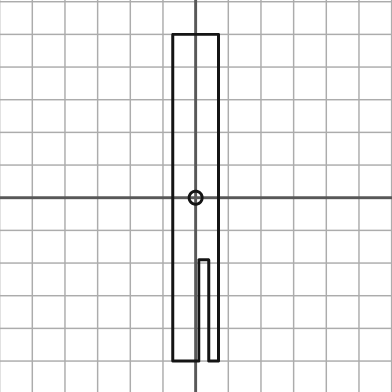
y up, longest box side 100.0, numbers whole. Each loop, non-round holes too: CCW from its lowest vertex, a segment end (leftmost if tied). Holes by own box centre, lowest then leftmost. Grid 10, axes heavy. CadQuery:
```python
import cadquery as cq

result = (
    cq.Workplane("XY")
    .moveTo(-7.0, -50.0)
    .lineTo(1.0, -50.0)
    .lineTo(1.0, -19.0)
    .lineTo(4.0, -19.0)
    .lineTo(4.0, -50.0)
    .lineTo(7.0, -50.0)
    .lineTo(7.0, 50.0)
    .lineTo(-7.0, 50.0)
    .close()
    .moveTo(0.0, 0.0)
    .circle(2.0)
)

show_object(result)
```